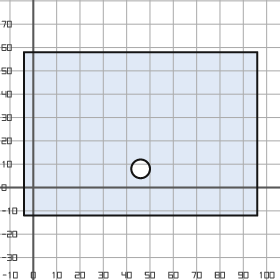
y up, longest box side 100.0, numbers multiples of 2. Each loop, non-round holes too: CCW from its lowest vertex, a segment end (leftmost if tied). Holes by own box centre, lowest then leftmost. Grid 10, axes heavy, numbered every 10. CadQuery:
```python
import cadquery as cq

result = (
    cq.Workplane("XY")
    .moveTo(-4.0, -12.0)
    .lineTo(96.0, -12.0)
    .lineTo(96.0, 58.0)
    .lineTo(-4.0, 58.0)
    .close()
    .moveTo(46.0, 8.0)
    .circle(4.0)
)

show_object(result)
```